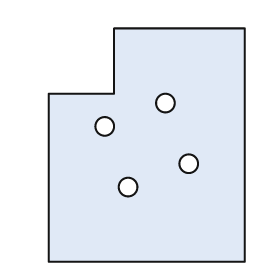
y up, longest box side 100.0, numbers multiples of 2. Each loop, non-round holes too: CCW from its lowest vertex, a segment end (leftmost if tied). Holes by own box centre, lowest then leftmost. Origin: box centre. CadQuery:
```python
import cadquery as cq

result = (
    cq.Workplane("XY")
    .moveTo(-42.0, -50.0)
    .lineTo(42.0, -50.0)
    .lineTo(42.0, 50.0)
    .lineTo(-14.0, 50.0)
    .lineTo(-14.0, 22.0)
    .lineTo(-42.0, 22.0)
    .close()
    .moveTo(-8.0, -18.0)
    .circle(4.0)
    .moveTo(18.0, -8.0)
    .circle(4.0)
    .moveTo(-18.0, 8.0)
    .circle(4.0)
    .moveTo(8.0, 18.0)
    .circle(4.0)
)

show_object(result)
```